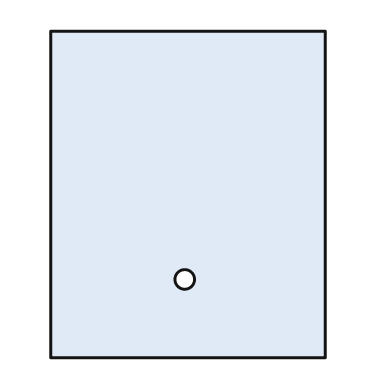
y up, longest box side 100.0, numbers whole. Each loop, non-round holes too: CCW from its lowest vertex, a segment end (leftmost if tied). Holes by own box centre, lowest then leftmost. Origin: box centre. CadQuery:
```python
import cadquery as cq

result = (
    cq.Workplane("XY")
    .moveTo(-42.0, -50.0)
    .lineTo(42.0, -50.0)
    .lineTo(42.0, 50.0)
    .lineTo(-42.0, 50.0)
    .close()
    .moveTo(-1.0, -26.0)
    .circle(3.0)
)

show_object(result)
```